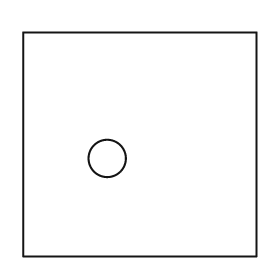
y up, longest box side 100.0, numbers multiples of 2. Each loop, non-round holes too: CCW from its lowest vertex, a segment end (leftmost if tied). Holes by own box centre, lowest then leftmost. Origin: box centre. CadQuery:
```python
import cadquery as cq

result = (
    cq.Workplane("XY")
    .moveTo(-50.0, -48.0)
    .lineTo(50.0, -48.0)
    .lineTo(50.0, 48.0)
    .lineTo(-50.0, 48.0)
    .close()
    .moveTo(-14.0, -6.0)
    .circle(8.0)
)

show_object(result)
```